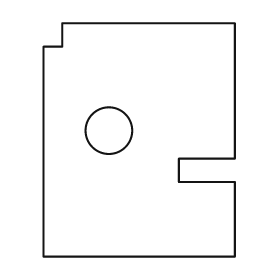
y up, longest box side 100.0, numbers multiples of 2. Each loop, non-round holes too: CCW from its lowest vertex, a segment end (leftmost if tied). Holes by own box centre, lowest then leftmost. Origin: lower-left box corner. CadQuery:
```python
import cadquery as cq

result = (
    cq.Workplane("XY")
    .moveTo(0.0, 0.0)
    .lineTo(82.0, 0.0)
    .lineTo(82.0, 32.0)
    .lineTo(58.0, 32.0)
    .lineTo(58.0, 42.0)
    .lineTo(82.0, 42.0)
    .lineTo(82.0, 100.0)
    .lineTo(8.0, 100.0)
    .lineTo(8.0, 90.0)
    .lineTo(0.0, 90.0)
    .close()
    .moveTo(28.0, 54.0)
    .circle(10.0)
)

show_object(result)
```